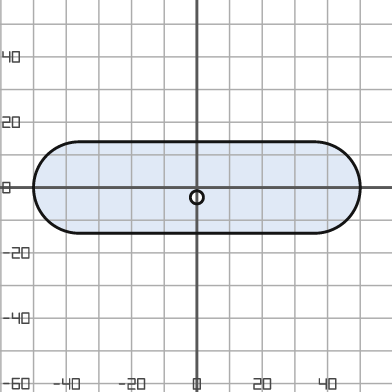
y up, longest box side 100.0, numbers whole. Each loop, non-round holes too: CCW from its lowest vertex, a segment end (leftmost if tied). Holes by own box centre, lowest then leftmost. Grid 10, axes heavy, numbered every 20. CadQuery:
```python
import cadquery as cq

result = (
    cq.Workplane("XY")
    .moveTo(-36.0, -14.0)
    .lineTo(36.0, -14.0)
    .threePointArc((50.0, 0.0), (36.0, 14.0))
    .lineTo(-36.0, 14.0)
    .threePointArc((-50.0, 0.0), (-36.0, -14.0))
    .close()
    .moveTo(0.0, -3.0)
    .circle(2.0)
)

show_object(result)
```